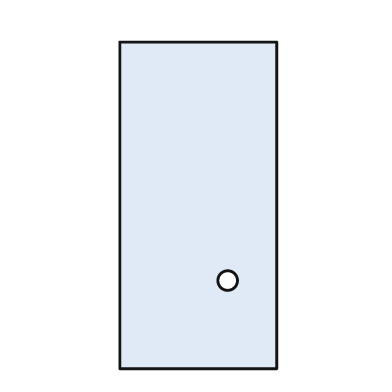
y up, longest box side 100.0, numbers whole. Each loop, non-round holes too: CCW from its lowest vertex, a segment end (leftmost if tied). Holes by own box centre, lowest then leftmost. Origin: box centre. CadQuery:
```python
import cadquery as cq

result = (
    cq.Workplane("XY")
    .moveTo(-24.0, -50.0)
    .lineTo(24.0, -50.0)
    .lineTo(24.0, 50.0)
    .lineTo(-24.0, 50.0)
    .close()
    .moveTo(9.0, -23.0)
    .circle(3.0)
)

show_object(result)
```